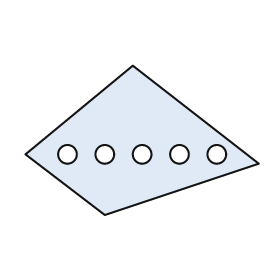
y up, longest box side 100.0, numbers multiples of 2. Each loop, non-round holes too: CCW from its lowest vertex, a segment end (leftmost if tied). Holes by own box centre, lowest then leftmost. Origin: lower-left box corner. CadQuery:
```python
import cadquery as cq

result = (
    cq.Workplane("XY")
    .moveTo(34.0, 0.0)
    .lineTo(100.0, 22.0)
    .lineTo(46.0, 64.0)
    .lineTo(0.0, 26.0)
    .close()
    .moveTo(18.0, 26.0)
    .circle(4.0)
    .moveTo(34.0, 26.0)
    .circle(4.0)
    .moveTo(50.0, 26.0)
    .circle(4.0)
    .moveTo(66.0, 26.0)
    .circle(4.0)
    .moveTo(82.0, 26.0)
    .circle(4.0)
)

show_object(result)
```